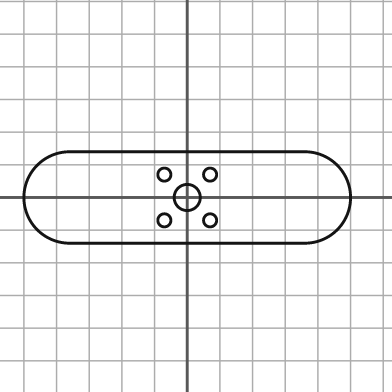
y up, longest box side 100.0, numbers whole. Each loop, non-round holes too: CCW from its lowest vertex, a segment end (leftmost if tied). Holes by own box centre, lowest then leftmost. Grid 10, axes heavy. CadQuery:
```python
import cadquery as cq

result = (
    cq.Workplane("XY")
    .moveTo(-36.0, -14.0)
    .lineTo(36.0, -14.0)
    .threePointArc((50.0, 0.0), (36.0, 14.0))
    .lineTo(-36.0, 14.0)
    .threePointArc((-50.0, 0.0), (-36.0, -14.0))
    .close()
    .moveTo(-7.0, -7.0)
    .circle(2.0)
    .moveTo(7.0, -7.0)
    .circle(2.0)
    .moveTo(0.0, 0.0)
    .circle(4.0)
    .moveTo(-7.0, 7.0)
    .circle(2.0)
    .moveTo(7.0, 7.0)
    .circle(2.0)
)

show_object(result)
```